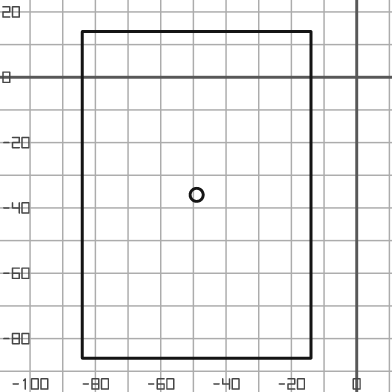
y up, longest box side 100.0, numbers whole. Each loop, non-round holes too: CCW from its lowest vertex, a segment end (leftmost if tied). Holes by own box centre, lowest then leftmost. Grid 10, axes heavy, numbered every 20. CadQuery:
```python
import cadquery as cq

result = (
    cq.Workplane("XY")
    .moveTo(-84.0, -86.0)
    .lineTo(-14.0, -86.0)
    .lineTo(-14.0, 14.0)
    .lineTo(-84.0, 14.0)
    .close()
    .moveTo(-49.0, -36.0)
    .circle(2.0)
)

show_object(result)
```